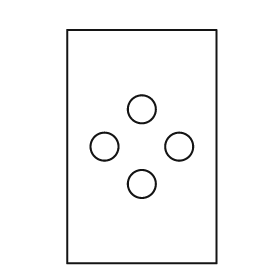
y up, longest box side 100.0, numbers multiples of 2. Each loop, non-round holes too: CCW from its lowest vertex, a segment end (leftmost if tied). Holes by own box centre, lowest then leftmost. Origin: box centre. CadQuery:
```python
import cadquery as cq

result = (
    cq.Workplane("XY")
    .moveTo(-32.0, -50.0)
    .lineTo(32.0, -50.0)
    .lineTo(32.0, 50.0)
    .lineTo(-32.0, 50.0)
    .close()
    .moveTo(0.0, -16.0)
    .circle(6.0)
    .moveTo(-16.0, 0.0)
    .circle(6.0)
    .moveTo(16.0, 0.0)
    .circle(6.0)
    .moveTo(0.0, 16.0)
    .circle(6.0)
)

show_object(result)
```